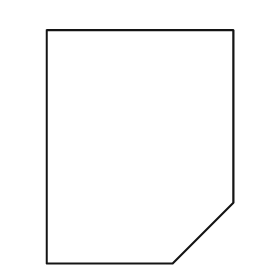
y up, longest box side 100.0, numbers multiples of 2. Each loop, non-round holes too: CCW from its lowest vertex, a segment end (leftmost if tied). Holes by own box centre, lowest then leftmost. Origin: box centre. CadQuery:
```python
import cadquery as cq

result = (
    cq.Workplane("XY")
    .moveTo(-40.0, -50.0)
    .lineTo(14.0, -50.0)
    .lineTo(40.0, -24.0)
    .lineTo(40.0, 50.0)
    .lineTo(-40.0, 50.0)
    .close()
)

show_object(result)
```